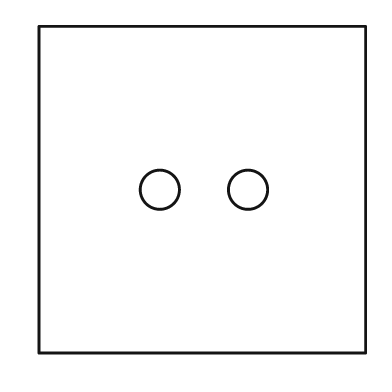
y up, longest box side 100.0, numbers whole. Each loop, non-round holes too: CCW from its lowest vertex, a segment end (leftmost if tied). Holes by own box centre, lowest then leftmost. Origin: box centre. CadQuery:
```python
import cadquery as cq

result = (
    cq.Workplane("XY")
    .moveTo(-50.0, -50.0)
    .lineTo(50.0, -50.0)
    .lineTo(50.0, 50.0)
    .lineTo(-50.0, 50.0)
    .close()
    .moveTo(-13.0, 0.0)
    .circle(6.0)
    .moveTo(14.0, 0.0)
    .circle(6.0)
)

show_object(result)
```